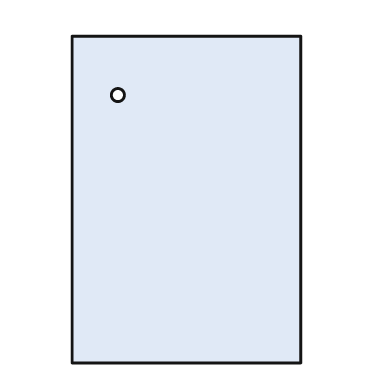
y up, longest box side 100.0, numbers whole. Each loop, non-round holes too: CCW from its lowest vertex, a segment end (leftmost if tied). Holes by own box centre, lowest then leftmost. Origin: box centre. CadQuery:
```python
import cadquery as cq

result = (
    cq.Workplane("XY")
    .moveTo(-35.0, -50.0)
    .lineTo(35.0, -50.0)
    .lineTo(35.0, 50.0)
    .lineTo(-35.0, 50.0)
    .close()
    .moveTo(-21.0, 32.0)
    .circle(2.0)
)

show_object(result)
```